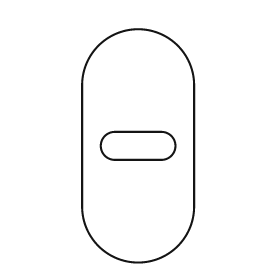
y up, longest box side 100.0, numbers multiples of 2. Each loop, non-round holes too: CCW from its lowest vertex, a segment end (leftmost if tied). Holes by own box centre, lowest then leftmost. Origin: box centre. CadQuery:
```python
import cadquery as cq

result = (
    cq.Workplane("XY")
    .moveTo(-24.0, -26.0)
    .threePointArc((0.0, -50.0), (24.0, -26.0))
    .lineTo(24.0, 26.0)
    .threePointArc((0.0, 50.0), (-24.0, 26.0))
    .close()
    .moveTo(-10.0, -6.0)
    .lineTo(10.0, -6.0)
    .threePointArc((16.0, 0.0), (10.0, 6.0))
    .lineTo(-10.0, 6.0)
    .threePointArc((-16.0, 0.0), (-10.0, -6.0))
    .close()
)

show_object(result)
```